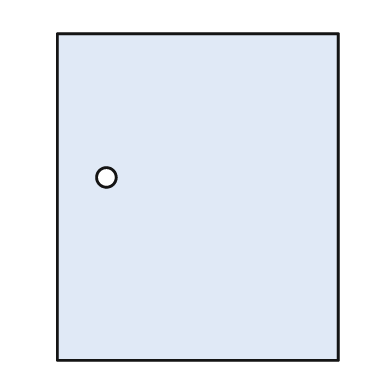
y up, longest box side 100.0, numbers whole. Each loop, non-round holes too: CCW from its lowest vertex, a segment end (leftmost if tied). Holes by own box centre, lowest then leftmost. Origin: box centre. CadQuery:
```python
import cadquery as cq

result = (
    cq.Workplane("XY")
    .moveTo(-43.0, -50.0)
    .lineTo(43.0, -50.0)
    .lineTo(43.0, 50.0)
    .lineTo(-43.0, 50.0)
    .close()
    .moveTo(-28.0, 6.0)
    .circle(3.0)
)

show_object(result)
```